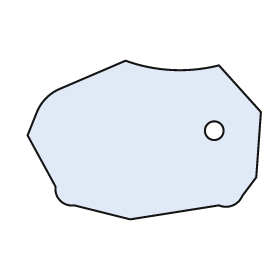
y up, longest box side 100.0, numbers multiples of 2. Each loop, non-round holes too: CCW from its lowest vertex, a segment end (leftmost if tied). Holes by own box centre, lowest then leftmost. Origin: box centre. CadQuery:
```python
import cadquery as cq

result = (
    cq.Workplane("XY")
    .moveTo(-6.0, -34.0)
    .lineTo(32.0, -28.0)
    .threePointArc((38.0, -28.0), (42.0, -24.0))
    .lineTo(48.0, -16.0)
    .lineTo(50.0, 12.0)
    .lineTo(32.0, 32.0)
    .threePointArc((12.0, 30.0), (-8.0, 34.0))
    .lineTo(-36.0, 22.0)
    .threePointArc((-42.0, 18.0), (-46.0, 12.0))
    .lineTo(-50.0, 2.0)
    .lineTo(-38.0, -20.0)
    .threePointArc((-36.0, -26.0), (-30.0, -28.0))
    .close()
    .moveTo(30.0, 4.0)
    .circle(4.0)
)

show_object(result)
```